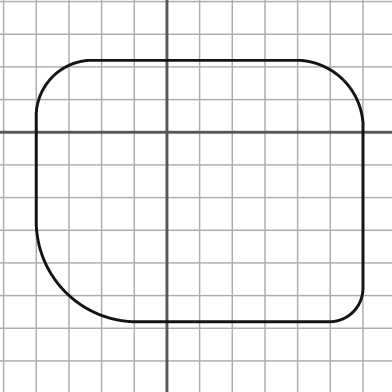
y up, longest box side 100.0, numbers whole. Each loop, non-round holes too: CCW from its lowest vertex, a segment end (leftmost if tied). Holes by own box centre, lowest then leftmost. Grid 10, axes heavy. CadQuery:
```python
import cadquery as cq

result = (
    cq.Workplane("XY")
    .moveTo(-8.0, -58.0)
    .lineTo(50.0, -58.0)
    .threePointArc((57.0, -55.0), (60.0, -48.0))
    .lineTo(60.0, 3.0)
    .threePointArc((54.0, 16.0), (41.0, 22.0))
    .lineTo(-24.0, 22.0)
    .threePointArc((-35.0, 17.0), (-40.0, 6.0))
    .lineTo(-40.0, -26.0)
    .threePointArc((-31.0, -49.0), (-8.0, -58.0))
    .close()
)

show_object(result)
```